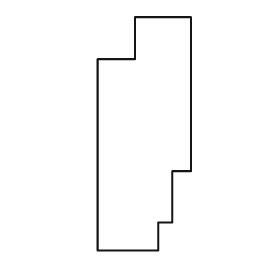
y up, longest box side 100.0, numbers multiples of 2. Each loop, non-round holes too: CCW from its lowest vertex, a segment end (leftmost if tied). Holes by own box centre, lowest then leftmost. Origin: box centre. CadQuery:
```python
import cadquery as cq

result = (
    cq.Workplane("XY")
    .moveTo(-20.0, -50.0)
    .lineTo(6.0, -50.0)
    .lineTo(6.0, -38.0)
    .lineTo(12.0, -38.0)
    .lineTo(12.0, -16.0)
    .lineTo(20.0, -16.0)
    .lineTo(20.0, 50.0)
    .lineTo(-4.0, 50.0)
    .lineTo(-4.0, 32.0)
    .lineTo(-20.0, 32.0)
    .close()
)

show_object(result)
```